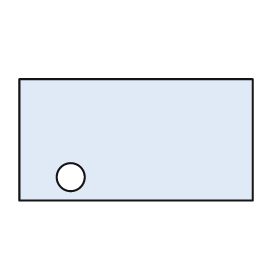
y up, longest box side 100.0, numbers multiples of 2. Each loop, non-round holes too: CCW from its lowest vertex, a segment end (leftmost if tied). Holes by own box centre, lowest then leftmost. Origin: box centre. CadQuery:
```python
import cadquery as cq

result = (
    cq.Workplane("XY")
    .moveTo(-50.0, -26.0)
    .lineTo(50.0, -26.0)
    .lineTo(50.0, 26.0)
    .lineTo(-50.0, 26.0)
    .close()
    .moveTo(-28.0, -16.0)
    .circle(6.0)
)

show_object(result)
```